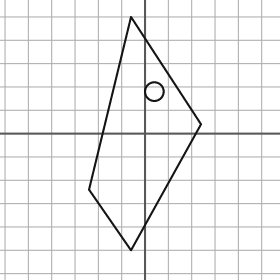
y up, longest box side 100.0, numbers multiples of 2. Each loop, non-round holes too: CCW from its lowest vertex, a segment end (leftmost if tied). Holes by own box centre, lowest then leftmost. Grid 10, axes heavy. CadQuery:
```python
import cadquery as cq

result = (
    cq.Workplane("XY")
    .moveTo(-6.0, -50.0)
    .lineTo(24.0, 4.0)
    .lineTo(-6.0, 50.0)
    .lineTo(-24.0, -24.0)
    .close()
    .moveTo(4.0, 18.0)
    .circle(4.0)
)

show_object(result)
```